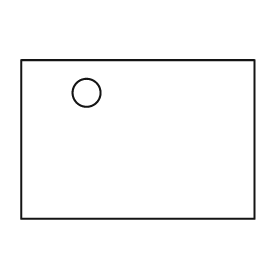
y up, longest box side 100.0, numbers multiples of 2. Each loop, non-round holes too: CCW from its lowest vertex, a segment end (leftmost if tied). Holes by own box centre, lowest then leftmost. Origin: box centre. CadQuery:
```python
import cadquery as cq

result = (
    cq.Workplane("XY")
    .moveTo(-50.0, -34.0)
    .lineTo(50.0, -34.0)
    .lineTo(50.0, 34.0)
    .lineTo(-50.0, 34.0)
    .close()
    .moveTo(-22.0, 20.0)
    .circle(6.0)
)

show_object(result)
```